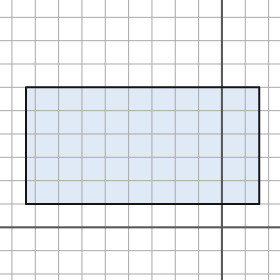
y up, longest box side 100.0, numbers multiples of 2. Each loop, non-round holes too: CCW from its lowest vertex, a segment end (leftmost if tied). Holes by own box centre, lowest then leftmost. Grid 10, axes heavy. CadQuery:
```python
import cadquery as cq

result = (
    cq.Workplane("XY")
    .moveTo(-84.0, 10.0)
    .lineTo(16.0, 10.0)
    .lineTo(16.0, 60.0)
    .lineTo(-84.0, 60.0)
    .close()
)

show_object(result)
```